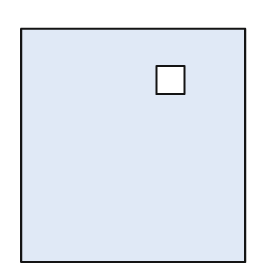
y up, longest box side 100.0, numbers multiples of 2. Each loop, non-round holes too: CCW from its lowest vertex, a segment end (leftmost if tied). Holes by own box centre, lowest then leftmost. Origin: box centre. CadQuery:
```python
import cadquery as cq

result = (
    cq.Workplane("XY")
    .moveTo(-48.0, -50.0)
    .lineTo(48.0, -50.0)
    .lineTo(48.0, 50.0)
    .lineTo(-48.0, 50.0)
    .close()
    .moveTo(10.0, 22.0)
    .lineTo(22.0, 22.0)
    .lineTo(22.0, 34.0)
    .lineTo(10.0, 34.0)
    .close()
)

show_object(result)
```